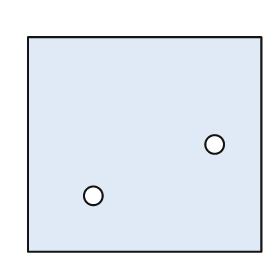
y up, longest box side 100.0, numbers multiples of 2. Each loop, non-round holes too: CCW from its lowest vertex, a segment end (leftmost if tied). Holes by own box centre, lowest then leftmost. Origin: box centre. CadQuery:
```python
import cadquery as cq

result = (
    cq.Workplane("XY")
    .moveTo(-50.0, -46.0)
    .lineTo(50.0, -46.0)
    .lineTo(50.0, 46.0)
    .lineTo(-50.0, 46.0)
    .close()
    .moveTo(-22.0, -22.0)
    .circle(4.0)
    .moveTo(30.0, 0.0)
    .circle(4.0)
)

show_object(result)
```